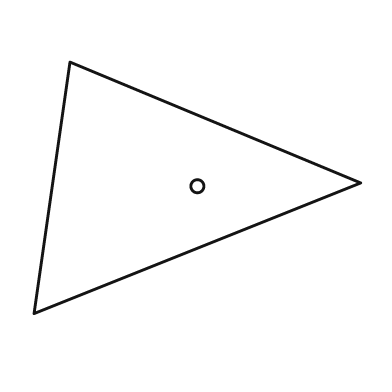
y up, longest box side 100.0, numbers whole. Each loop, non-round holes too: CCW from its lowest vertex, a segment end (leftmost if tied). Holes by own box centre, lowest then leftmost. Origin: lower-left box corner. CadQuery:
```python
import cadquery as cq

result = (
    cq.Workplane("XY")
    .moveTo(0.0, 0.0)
    .lineTo(100.0, 40.0)
    .lineTo(11.0, 77.0)
    .close()
    .moveTo(50.0, 39.0)
    .circle(2.0)
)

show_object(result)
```